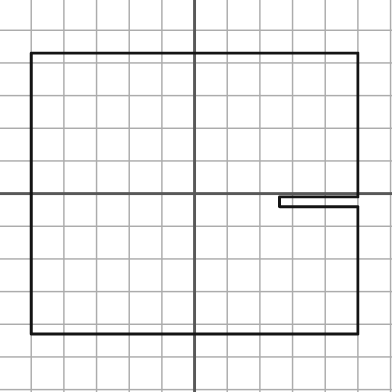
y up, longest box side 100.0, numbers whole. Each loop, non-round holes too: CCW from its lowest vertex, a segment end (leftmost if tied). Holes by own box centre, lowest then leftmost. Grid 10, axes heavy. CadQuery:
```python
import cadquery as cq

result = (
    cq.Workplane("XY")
    .moveTo(-50.0, -43.0)
    .lineTo(50.0, -43.0)
    .lineTo(50.0, -4.0)
    .lineTo(26.0, -4.0)
    .lineTo(26.0, -1.0)
    .lineTo(50.0, -1.0)
    .lineTo(50.0, 43.0)
    .lineTo(-50.0, 43.0)
    .close()
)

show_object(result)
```